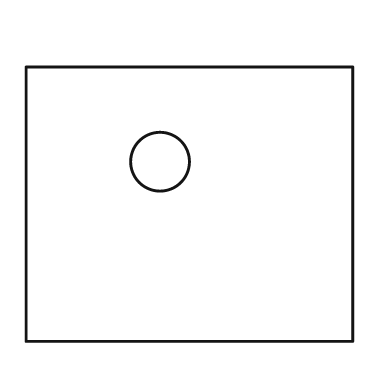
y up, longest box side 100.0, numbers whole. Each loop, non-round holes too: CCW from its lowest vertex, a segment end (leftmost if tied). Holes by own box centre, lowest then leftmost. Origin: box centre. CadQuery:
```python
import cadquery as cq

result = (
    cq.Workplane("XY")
    .moveTo(-50.0, -42.0)
    .lineTo(50.0, -42.0)
    .lineTo(50.0, 42.0)
    .lineTo(-50.0, 42.0)
    .close()
    .moveTo(-9.0, 13.0)
    .circle(9.0)
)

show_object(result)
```